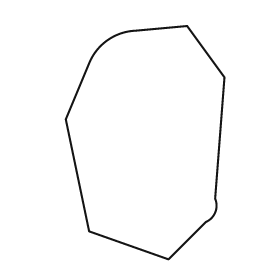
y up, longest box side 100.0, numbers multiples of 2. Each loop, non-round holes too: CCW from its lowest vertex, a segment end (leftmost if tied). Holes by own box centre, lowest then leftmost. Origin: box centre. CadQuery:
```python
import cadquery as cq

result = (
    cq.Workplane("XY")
    .moveTo(10.0, -50.0)
    .lineTo(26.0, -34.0)
    .threePointArc((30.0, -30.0), (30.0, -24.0))
    .lineTo(34.0, 28.0)
    .lineTo(18.0, 50.0)
    .lineTo(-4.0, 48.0)
    .threePointArc((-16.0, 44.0), (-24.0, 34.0))
    .lineTo(-34.0, 10.0)
    .lineTo(-24.0, -38.0)
    .close()
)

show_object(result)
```